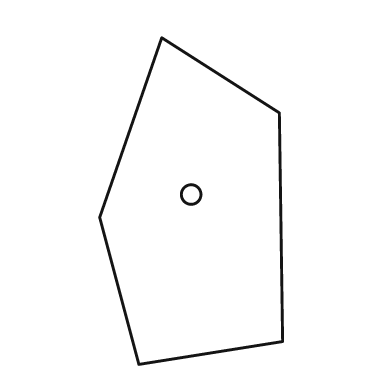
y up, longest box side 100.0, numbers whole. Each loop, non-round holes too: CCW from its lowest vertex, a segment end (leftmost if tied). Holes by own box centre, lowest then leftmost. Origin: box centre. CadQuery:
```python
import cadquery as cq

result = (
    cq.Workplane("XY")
    .moveTo(-16.0, -50.0)
    .lineTo(28.0, -43.0)
    .lineTo(27.0, 27.0)
    .lineTo(-9.0, 50.0)
    .lineTo(-28.0, -5.0)
    .close()
    .moveTo(0.0, 2.0)
    .circle(3.0)
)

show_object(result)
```